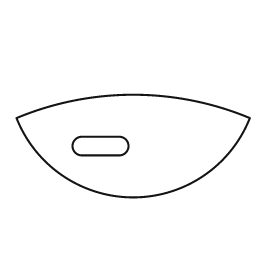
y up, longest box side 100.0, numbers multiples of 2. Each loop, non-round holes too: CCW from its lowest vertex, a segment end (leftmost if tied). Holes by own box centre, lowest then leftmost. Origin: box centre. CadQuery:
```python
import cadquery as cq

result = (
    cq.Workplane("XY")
    .moveTo(-50.0, 12.0)
    .threePointArc((0.0, -22.0), (50.0, 12.0))
    .threePointArc((0.0, 22.0), (-50.0, 12.0))
    .close()
    .moveTo(-22.0, -4.0)
    .lineTo(-6.0, -4.0)
    .threePointArc((-2.0, 0.0), (-6.0, 4.0))
    .lineTo(-22.0, 4.0)
    .threePointArc((-26.0, 0.0), (-22.0, -4.0))
    .close()
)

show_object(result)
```